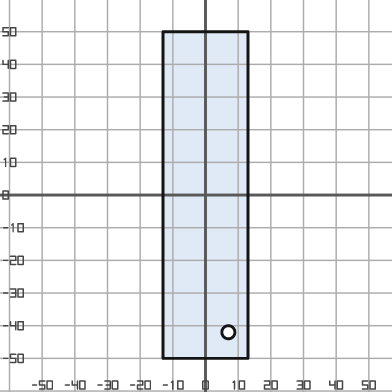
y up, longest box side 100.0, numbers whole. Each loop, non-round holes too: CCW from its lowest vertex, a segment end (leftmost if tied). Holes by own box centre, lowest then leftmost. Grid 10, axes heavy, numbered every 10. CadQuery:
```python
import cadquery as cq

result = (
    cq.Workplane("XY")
    .moveTo(-13.0, -50.0)
    .lineTo(13.0, -50.0)
    .lineTo(13.0, 50.0)
    .lineTo(-13.0, 50.0)
    .close()
    .moveTo(7.0, -42.0)
    .circle(2.0)
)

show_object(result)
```